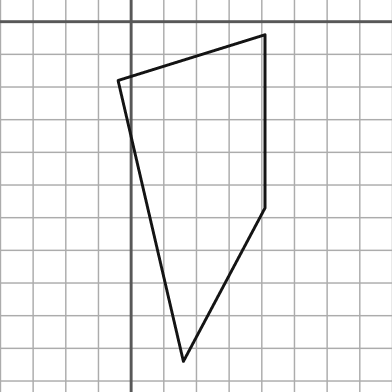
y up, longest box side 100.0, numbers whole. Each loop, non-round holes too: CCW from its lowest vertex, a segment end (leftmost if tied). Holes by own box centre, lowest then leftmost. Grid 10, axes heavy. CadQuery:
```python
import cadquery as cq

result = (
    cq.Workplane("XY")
    .moveTo(16.0, -104.0)
    .lineTo(41.0, -57.0)
    .lineTo(41.0, -4.0)
    .lineTo(-4.0, -18.0)
    .close()
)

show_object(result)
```